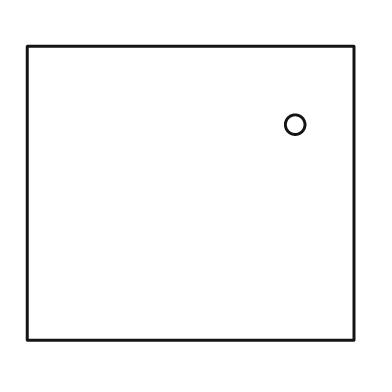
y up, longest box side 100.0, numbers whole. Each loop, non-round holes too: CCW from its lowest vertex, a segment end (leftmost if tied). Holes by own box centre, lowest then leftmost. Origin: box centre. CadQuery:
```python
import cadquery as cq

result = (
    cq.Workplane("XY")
    .moveTo(-50.0, -45.0)
    .lineTo(50.0, -45.0)
    .lineTo(50.0, 45.0)
    .lineTo(-50.0, 45.0)
    .close()
    .moveTo(32.0, 21.0)
    .circle(3.0)
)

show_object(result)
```